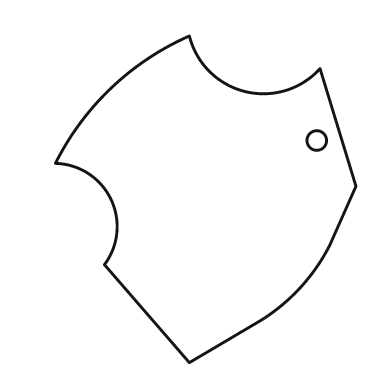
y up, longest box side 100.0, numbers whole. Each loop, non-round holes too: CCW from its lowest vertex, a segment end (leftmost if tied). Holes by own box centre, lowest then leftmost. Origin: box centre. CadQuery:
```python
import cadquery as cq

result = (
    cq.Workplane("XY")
    .moveTo(-5.0, -50.0)
    .lineTo(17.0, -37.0)
    .threePointArc((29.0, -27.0), (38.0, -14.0))
    .lineTo(46.0, 4.0)
    .lineTo(35.0, 40.0)
    .threePointArc((12.0, 33.0), (-5.0, 50.0))
    .threePointArc((-29.0, 34.0), (-46.0, 11.0))
    .threePointArc((-29.0, 0.0), (-31.0, -20.0))
    .close()
    .moveTo(34.0, 18.0)
    .circle(3.0)
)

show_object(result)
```